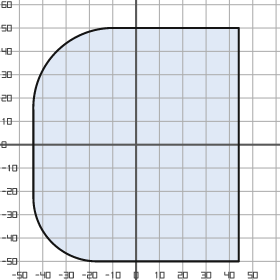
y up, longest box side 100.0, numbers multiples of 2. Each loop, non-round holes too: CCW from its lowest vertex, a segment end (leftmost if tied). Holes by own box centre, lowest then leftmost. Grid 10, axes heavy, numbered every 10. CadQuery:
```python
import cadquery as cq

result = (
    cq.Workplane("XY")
    .moveTo(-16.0, -50.0)
    .lineTo(44.0, -50.0)
    .lineTo(44.0, 50.0)
    .lineTo(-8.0, 50.0)
    .threePointArc((-34.0, 40.0), (-44.0, 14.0))
    .lineTo(-44.0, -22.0)
    .threePointArc((-36.0, -42.0), (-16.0, -50.0))
    .close()
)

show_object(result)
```